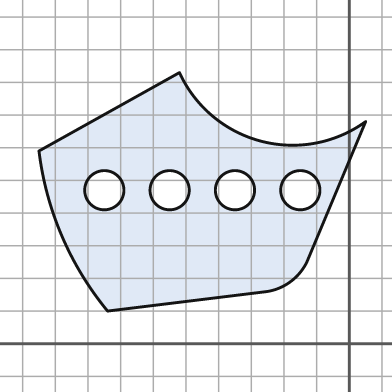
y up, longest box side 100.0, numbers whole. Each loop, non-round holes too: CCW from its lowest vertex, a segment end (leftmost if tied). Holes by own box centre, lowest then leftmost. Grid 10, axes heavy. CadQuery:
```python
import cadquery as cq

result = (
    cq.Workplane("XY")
    .moveTo(-74.0, 10.0)
    .lineTo(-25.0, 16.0)
    .threePointArc((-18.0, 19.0), (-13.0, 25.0))
    .lineTo(5.0, 68.0)
    .threePointArc((-27.0, 62.0), (-52.0, 83.0))
    .lineTo(-95.0, 59.0)
    .threePointArc((-88.0, 33.0), (-74.0, 10.0))
    .close()
    .moveTo(-75.0, 47.0)
    .circle(6.0)
    .moveTo(-55.0, 47.0)
    .circle(6.0)
    .moveTo(-35.0, 47.0)
    .circle(6.0)
    .moveTo(-15.0, 47.0)
    .circle(6.0)
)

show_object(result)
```